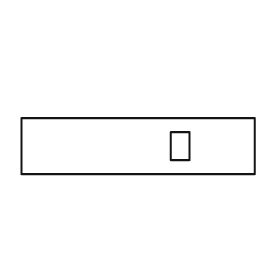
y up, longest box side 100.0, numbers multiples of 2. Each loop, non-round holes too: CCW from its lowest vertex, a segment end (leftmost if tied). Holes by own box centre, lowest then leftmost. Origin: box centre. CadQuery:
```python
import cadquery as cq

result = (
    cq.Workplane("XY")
    .moveTo(-50.0, -12.0)
    .lineTo(50.0, -12.0)
    .lineTo(50.0, 12.0)
    .lineTo(-50.0, 12.0)
    .close()
    .moveTo(14.0, -6.0)
    .lineTo(22.0, -6.0)
    .lineTo(22.0, 6.0)
    .lineTo(14.0, 6.0)
    .close()
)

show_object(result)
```